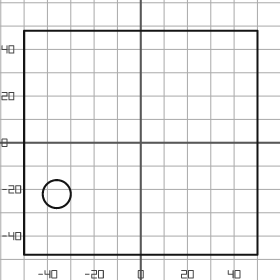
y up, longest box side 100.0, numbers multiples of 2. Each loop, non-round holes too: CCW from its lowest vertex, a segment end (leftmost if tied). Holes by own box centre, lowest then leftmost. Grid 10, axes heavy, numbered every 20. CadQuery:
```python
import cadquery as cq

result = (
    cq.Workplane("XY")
    .moveTo(-50.0, -48.0)
    .lineTo(50.0, -48.0)
    .lineTo(50.0, 48.0)
    .lineTo(-50.0, 48.0)
    .close()
    .moveTo(-36.0, -22.0)
    .circle(6.0)
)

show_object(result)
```